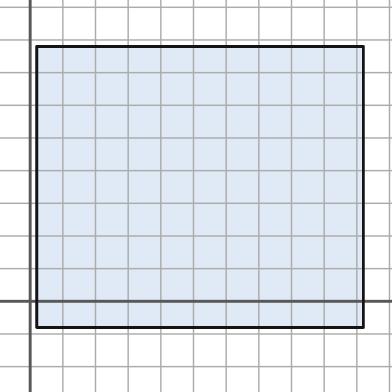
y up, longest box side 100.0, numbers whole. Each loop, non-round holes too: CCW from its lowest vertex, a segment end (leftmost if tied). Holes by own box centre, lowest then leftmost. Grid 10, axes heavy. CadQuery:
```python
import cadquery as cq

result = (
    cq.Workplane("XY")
    .moveTo(2.0, -8.0)
    .lineTo(102.0, -8.0)
    .lineTo(102.0, 78.0)
    .lineTo(2.0, 78.0)
    .close()
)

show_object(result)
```